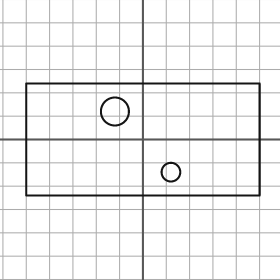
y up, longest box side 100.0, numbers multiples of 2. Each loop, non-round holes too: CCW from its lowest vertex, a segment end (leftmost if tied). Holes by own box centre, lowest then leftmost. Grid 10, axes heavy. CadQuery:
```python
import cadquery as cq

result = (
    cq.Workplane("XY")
    .moveTo(-50.0, -24.0)
    .lineTo(50.0, -24.0)
    .lineTo(50.0, 24.0)
    .lineTo(-50.0, 24.0)
    .close()
    .moveTo(12.0, -14.0)
    .circle(4.0)
    .moveTo(-12.0, 12.0)
    .circle(6.0)
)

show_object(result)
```